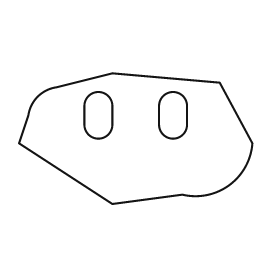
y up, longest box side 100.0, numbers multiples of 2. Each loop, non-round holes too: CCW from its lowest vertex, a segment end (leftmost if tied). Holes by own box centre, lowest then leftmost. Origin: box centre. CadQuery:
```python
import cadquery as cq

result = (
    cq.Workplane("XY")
    .moveTo(-10.0, -28.0)
    .lineTo(20.0, -24.0)
    .threePointArc((40.0, -20.0), (50.0, -2.0))
    .lineTo(36.0, 24.0)
    .lineTo(-10.0, 28.0)
    .lineTo(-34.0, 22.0)
    .threePointArc((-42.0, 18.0), (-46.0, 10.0))
    .lineTo(-50.0, -2.0)
    .close()
    .moveTo(-22.0, 6.0)
    .threePointArc((-16.0, 0.0), (-10.0, 6.0))
    .lineTo(-10.0, 14.0)
    .threePointArc((-16.0, 20.0), (-22.0, 14.0))
    .close()
    .moveTo(10.0, 6.0)
    .threePointArc((16.0, 0.0), (22.0, 6.0))
    .lineTo(22.0, 14.0)
    .threePointArc((16.0, 20.0), (10.0, 14.0))
    .close()
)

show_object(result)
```